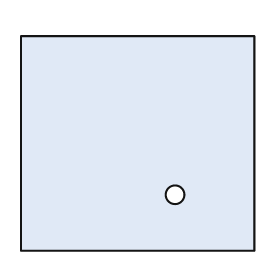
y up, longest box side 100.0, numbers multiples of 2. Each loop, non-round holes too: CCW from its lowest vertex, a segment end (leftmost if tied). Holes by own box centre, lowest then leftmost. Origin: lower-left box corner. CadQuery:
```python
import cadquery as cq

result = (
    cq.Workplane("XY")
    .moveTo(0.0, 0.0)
    .lineTo(100.0, 0.0)
    .lineTo(100.0, 92.0)
    .lineTo(0.0, 92.0)
    .close()
    .moveTo(66.0, 24.0)
    .circle(4.0)
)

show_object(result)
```